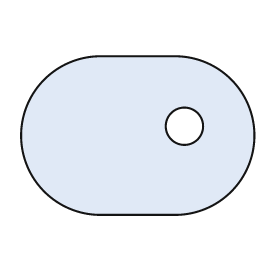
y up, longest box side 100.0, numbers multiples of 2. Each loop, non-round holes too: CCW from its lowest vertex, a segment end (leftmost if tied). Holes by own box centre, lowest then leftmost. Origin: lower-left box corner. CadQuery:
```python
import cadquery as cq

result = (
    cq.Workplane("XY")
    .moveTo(34.0, 0.0)
    .lineTo(66.0, 0.0)
    .threePointArc((100.0, 34.0), (66.0, 68.0))
    .lineTo(34.0, 68.0)
    .threePointArc((0.0, 34.0), (34.0, 0.0))
    .close()
    .moveTo(70.0, 38.0)
    .circle(8.0)
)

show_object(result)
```